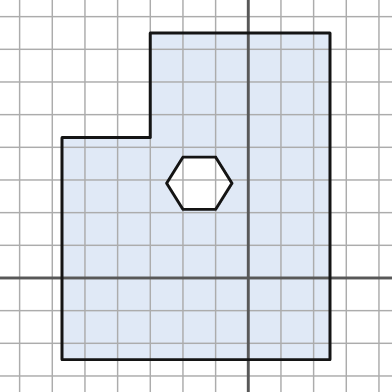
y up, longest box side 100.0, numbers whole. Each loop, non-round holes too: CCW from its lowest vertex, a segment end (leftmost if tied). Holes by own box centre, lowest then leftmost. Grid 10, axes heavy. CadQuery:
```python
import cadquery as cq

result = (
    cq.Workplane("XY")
    .moveTo(-57.0, -25.0)
    .lineTo(25.0, -25.0)
    .lineTo(25.0, 75.0)
    .lineTo(-30.0, 75.0)
    .lineTo(-30.0, 43.0)
    .lineTo(-57.0, 43.0)
    .close()
    .moveTo(-20.0, 21.0)
    .lineTo(-10.0, 21.0)
    .lineTo(-5.0, 29.0)
    .lineTo(-10.0, 37.0)
    .lineTo(-20.0, 37.0)
    .lineTo(-25.0, 29.0)
    .close()
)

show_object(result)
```